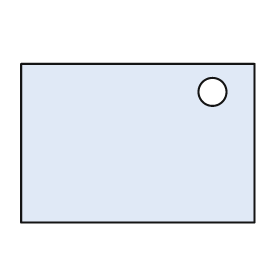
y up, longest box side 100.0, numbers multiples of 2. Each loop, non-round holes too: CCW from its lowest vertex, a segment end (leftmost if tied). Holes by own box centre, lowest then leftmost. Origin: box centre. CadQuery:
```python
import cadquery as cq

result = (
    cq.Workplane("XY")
    .moveTo(-50.0, -34.0)
    .lineTo(50.0, -34.0)
    .lineTo(50.0, 34.0)
    .lineTo(-50.0, 34.0)
    .close()
    .moveTo(32.0, 22.0)
    .circle(6.0)
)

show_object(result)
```